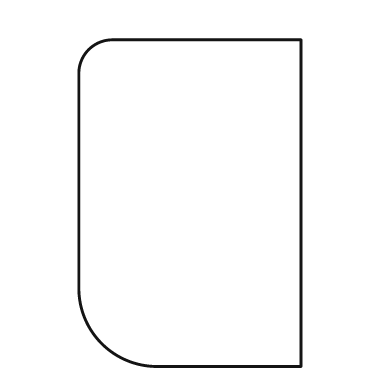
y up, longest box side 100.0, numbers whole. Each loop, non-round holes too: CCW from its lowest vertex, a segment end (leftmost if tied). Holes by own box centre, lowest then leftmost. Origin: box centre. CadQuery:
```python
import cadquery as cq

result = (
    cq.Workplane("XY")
    .moveTo(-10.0, -50.0)
    .lineTo(34.0, -50.0)
    .lineTo(34.0, 50.0)
    .lineTo(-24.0, 50.0)
    .threePointArc((-31.0, 47.0), (-34.0, 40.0))
    .lineTo(-34.0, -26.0)
    .threePointArc((-27.0, -43.0), (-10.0, -50.0))
    .close()
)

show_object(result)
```